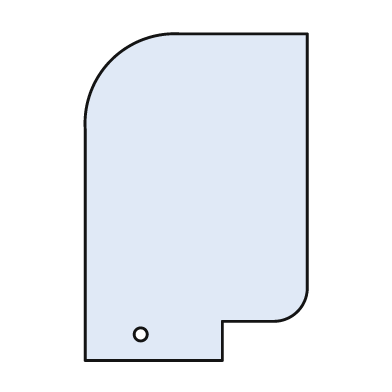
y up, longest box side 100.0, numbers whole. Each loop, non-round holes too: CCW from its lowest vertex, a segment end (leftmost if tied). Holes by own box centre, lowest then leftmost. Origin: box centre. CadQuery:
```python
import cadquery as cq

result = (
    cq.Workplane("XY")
    .moveTo(-34.0, -50.0)
    .lineTo(8.0, -50.0)
    .lineTo(8.0, -38.0)
    .lineTo(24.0, -38.0)
    .threePointArc((31.0, -35.0), (34.0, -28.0))
    .lineTo(34.0, 50.0)
    .lineTo(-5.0, 50.0)
    .threePointArc((-26.0, 42.0), (-34.0, 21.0))
    .close()
    .moveTo(-17.0, -42.0)
    .circle(2.0)
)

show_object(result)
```